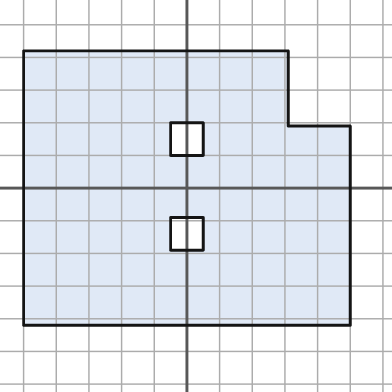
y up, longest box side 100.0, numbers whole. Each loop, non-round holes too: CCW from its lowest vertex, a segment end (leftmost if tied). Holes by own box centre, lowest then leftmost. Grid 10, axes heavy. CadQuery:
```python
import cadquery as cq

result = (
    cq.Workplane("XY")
    .moveTo(-50.0, -42.0)
    .lineTo(50.0, -42.0)
    .lineTo(50.0, 19.0)
    .lineTo(31.0, 19.0)
    .lineTo(31.0, 42.0)
    .lineTo(-50.0, 42.0)
    .close()
    .moveTo(-5.0, -19.0)
    .lineTo(5.0, -19.0)
    .lineTo(5.0, -9.0)
    .lineTo(-5.0, -9.0)
    .close()
    .moveTo(-5.0, 10.0)
    .lineTo(5.0, 10.0)
    .lineTo(5.0, 20.0)
    .lineTo(-5.0, 20.0)
    .close()
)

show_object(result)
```